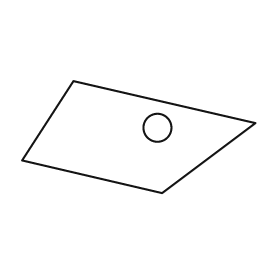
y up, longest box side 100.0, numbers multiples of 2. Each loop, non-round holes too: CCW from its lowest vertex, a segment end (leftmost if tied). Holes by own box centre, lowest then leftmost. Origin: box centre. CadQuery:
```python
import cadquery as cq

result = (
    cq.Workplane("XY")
    .moveTo(10.0, -24.0)
    .lineTo(50.0, 6.0)
    .lineTo(-28.0, 24.0)
    .lineTo(-50.0, -10.0)
    .close()
    .moveTo(8.0, 4.0)
    .circle(6.0)
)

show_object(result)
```